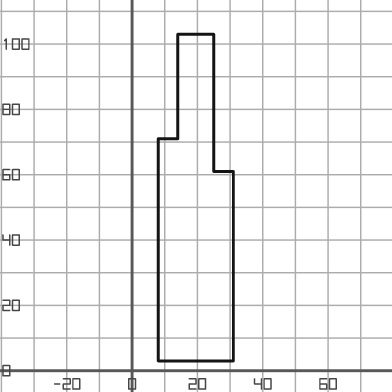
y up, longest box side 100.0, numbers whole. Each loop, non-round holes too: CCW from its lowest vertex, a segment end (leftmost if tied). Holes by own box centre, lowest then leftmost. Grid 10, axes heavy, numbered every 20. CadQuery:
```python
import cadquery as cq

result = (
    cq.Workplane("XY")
    .moveTo(8.0, 3.0)
    .lineTo(31.0, 3.0)
    .lineTo(31.0, 61.0)
    .lineTo(25.0, 61.0)
    .lineTo(25.0, 103.0)
    .lineTo(14.0, 103.0)
    .lineTo(14.0, 71.0)
    .lineTo(8.0, 71.0)
    .close()
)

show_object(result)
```